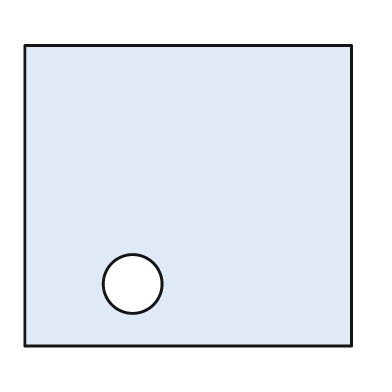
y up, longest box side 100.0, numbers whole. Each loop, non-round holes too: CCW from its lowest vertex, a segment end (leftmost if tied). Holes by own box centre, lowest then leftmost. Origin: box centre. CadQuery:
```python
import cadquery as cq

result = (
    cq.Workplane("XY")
    .moveTo(-50.0, -46.0)
    .lineTo(50.0, -46.0)
    .lineTo(50.0, 46.0)
    .lineTo(-50.0, 46.0)
    .close()
    .moveTo(-17.0, -27.0)
    .circle(9.0)
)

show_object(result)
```